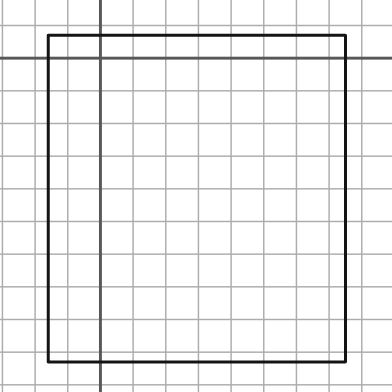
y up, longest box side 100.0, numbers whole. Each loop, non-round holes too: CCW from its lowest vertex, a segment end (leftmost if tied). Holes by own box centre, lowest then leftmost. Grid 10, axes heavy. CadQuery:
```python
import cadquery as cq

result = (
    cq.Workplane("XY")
    .moveTo(-16.0, -93.0)
    .lineTo(75.0, -93.0)
    .lineTo(75.0, 7.0)
    .lineTo(-16.0, 7.0)
    .close()
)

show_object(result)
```